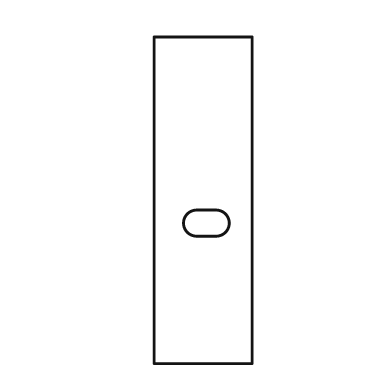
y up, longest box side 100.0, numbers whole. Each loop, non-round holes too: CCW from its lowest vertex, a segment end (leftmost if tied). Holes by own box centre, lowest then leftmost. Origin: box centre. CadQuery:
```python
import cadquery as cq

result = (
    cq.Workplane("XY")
    .moveTo(-15.0, -50.0)
    .lineTo(15.0, -50.0)
    .lineTo(15.0, 50.0)
    .lineTo(-15.0, 50.0)
    .close()
    .moveTo(-2.0, -11.0)
    .lineTo(4.0, -11.0)
    .threePointArc((8.0, -7.0), (4.0, -3.0))
    .lineTo(-2.0, -3.0)
    .threePointArc((-6.0, -7.0), (-2.0, -11.0))
    .close()
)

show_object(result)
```